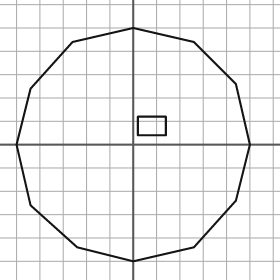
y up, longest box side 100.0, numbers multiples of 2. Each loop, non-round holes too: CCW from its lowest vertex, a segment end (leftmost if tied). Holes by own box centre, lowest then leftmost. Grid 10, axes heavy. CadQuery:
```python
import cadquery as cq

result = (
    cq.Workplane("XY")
    .moveTo(0.0, -50.0)
    .lineTo(26.0, -44.0)
    .lineTo(44.0, -24.0)
    .lineTo(50.0, 0.0)
    .lineTo(44.0, 26.0)
    .lineTo(26.0, 44.0)
    .lineTo(0.0, 50.0)
    .lineTo(-26.0, 44.0)
    .lineTo(-44.0, 24.0)
    .lineTo(-50.0, 0.0)
    .lineTo(-44.0, -26.0)
    .lineTo(-24.0, -44.0)
    .close()
    .moveTo(2.0, 4.0)
    .lineTo(14.0, 4.0)
    .lineTo(14.0, 12.0)
    .lineTo(2.0, 12.0)
    .close()
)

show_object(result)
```